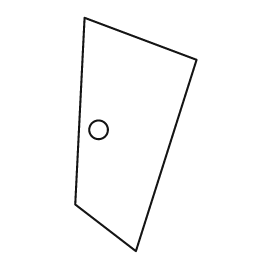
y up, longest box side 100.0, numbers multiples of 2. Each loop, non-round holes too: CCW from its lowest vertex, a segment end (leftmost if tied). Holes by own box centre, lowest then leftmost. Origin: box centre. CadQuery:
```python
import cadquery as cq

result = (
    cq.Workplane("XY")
    .moveTo(0.0, -50.0)
    .lineTo(26.0, 32.0)
    .lineTo(-22.0, 50.0)
    .lineTo(-26.0, -30.0)
    .close()
    .moveTo(-16.0, 2.0)
    .circle(4.0)
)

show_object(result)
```